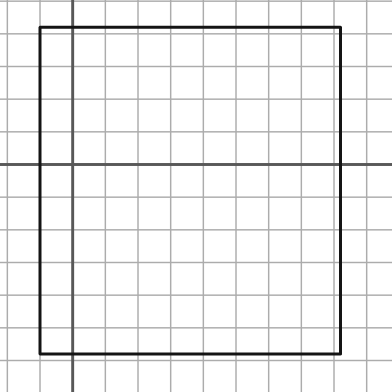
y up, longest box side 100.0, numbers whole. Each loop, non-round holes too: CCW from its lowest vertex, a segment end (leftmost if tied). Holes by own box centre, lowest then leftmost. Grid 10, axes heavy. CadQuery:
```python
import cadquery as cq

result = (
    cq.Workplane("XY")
    .moveTo(-10.0, -58.0)
    .lineTo(82.0, -58.0)
    .lineTo(82.0, 42.0)
    .lineTo(-10.0, 42.0)
    .close()
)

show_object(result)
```